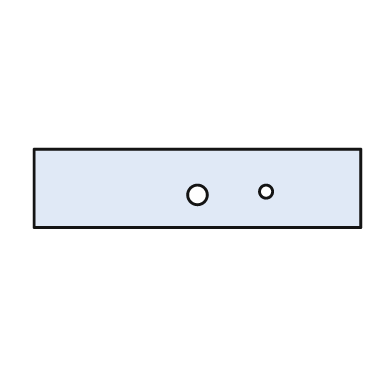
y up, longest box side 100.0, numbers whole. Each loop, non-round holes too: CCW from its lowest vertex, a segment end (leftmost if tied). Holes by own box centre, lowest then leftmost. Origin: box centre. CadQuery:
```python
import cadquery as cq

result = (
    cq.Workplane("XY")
    .moveTo(-50.0, -12.0)
    .lineTo(50.0, -12.0)
    .lineTo(50.0, 12.0)
    .lineTo(-50.0, 12.0)
    .close()
    .moveTo(0.0, -2.0)
    .circle(3.0)
    .moveTo(21.0, -1.0)
    .circle(2.0)
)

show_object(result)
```